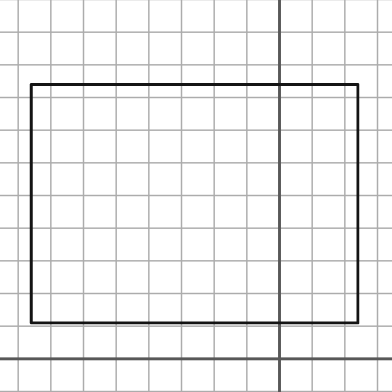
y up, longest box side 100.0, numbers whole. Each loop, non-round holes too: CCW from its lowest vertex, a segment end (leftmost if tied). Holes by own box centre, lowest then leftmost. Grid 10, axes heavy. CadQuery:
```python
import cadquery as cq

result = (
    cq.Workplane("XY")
    .moveTo(-76.0, 11.0)
    .lineTo(24.0, 11.0)
    .lineTo(24.0, 84.0)
    .lineTo(-76.0, 84.0)
    .close()
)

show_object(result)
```